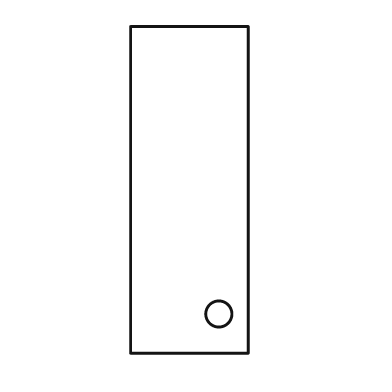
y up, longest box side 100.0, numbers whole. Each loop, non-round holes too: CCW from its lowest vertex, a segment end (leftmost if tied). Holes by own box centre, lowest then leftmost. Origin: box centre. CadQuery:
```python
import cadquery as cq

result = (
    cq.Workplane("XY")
    .moveTo(-18.0, -50.0)
    .lineTo(18.0, -50.0)
    .lineTo(18.0, 50.0)
    .lineTo(-18.0, 50.0)
    .close()
    .moveTo(9.0, -38.0)
    .circle(4.0)
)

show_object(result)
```